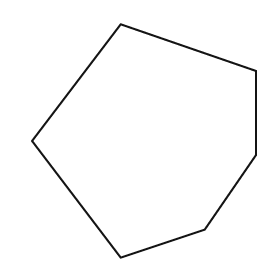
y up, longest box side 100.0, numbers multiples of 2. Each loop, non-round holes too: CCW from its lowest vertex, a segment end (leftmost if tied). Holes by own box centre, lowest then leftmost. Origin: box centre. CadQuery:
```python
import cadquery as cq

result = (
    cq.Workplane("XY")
    .moveTo(-10.0, -50.0)
    .lineTo(26.0, -38.0)
    .lineTo(48.0, -6.0)
    .lineTo(48.0, 30.0)
    .lineTo(-10.0, 50.0)
    .lineTo(-48.0, 0.0)
    .close()
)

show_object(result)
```